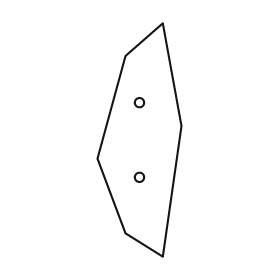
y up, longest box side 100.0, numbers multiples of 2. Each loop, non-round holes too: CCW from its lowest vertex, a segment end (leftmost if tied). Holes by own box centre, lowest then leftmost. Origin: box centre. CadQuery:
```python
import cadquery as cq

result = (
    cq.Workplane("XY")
    .moveTo(10.0, -50.0)
    .lineTo(18.0, 6.0)
    .lineTo(10.0, 50.0)
    .lineTo(-6.0, 36.0)
    .lineTo(-18.0, -8.0)
    .lineTo(-6.0, -40.0)
    .close()
    .moveTo(0.0, -16.0)
    .circle(2.0)
    .moveTo(0.0, 16.0)
    .circle(2.0)
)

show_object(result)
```